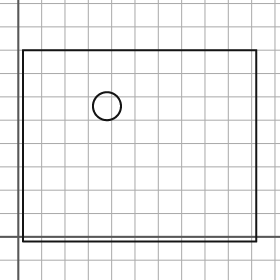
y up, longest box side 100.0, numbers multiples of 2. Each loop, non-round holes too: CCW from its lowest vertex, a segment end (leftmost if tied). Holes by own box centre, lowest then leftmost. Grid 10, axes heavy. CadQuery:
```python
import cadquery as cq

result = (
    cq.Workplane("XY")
    .moveTo(2.0, -2.0)
    .lineTo(102.0, -2.0)
    .lineTo(102.0, 80.0)
    .lineTo(2.0, 80.0)
    .close()
    .moveTo(38.0, 56.0)
    .circle(6.0)
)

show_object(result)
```